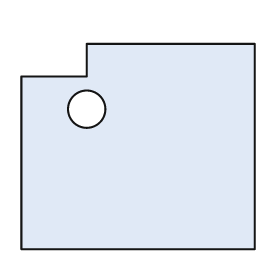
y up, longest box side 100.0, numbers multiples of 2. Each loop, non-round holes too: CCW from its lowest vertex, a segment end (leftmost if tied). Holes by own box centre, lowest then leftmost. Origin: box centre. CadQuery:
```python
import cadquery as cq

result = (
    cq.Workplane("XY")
    .moveTo(-50.0, -44.0)
    .lineTo(50.0, -44.0)
    .lineTo(50.0, 44.0)
    .lineTo(-22.0, 44.0)
    .lineTo(-22.0, 30.0)
    .lineTo(-50.0, 30.0)
    .close()
    .moveTo(-22.0, 16.0)
    .circle(8.0)
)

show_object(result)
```